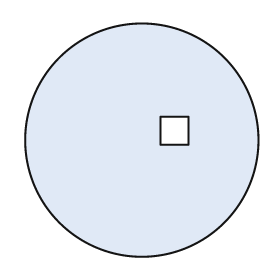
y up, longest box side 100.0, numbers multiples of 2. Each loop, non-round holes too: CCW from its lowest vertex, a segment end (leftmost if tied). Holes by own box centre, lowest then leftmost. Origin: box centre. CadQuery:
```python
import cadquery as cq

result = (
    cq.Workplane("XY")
    .moveTo(0.0, 0.0)
    .circle(50.0)
    .moveTo(8.0, -2.0)
    .lineTo(20.0, -2.0)
    .lineTo(20.0, 10.0)
    .lineTo(8.0, 10.0)
    .close()
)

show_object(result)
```